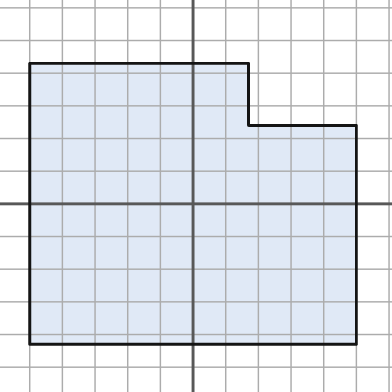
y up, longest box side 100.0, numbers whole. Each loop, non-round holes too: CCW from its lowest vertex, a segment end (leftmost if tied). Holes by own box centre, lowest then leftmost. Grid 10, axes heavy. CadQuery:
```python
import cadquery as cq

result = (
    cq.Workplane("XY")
    .moveTo(-50.0, -43.0)
    .lineTo(50.0, -43.0)
    .lineTo(50.0, 24.0)
    .lineTo(17.0, 24.0)
    .lineTo(17.0, 43.0)
    .lineTo(-50.0, 43.0)
    .close()
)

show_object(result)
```